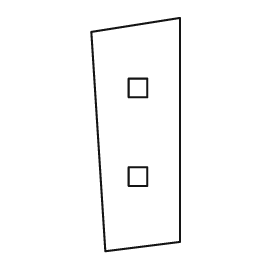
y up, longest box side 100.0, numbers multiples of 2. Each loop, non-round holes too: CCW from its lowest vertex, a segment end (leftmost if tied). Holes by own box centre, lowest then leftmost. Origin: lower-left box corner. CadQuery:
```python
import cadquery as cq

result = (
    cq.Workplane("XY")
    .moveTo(6.0, 0.0)
    .lineTo(38.0, 4.0)
    .lineTo(38.0, 100.0)
    .lineTo(0.0, 94.0)
    .close()
    .moveTo(16.0, 28.0)
    .lineTo(24.0, 28.0)
    .lineTo(24.0, 36.0)
    .lineTo(16.0, 36.0)
    .close()
    .moveTo(16.0, 66.0)
    .lineTo(24.0, 66.0)
    .lineTo(24.0, 74.0)
    .lineTo(16.0, 74.0)
    .close()
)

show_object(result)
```